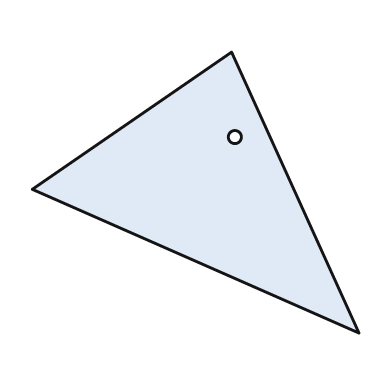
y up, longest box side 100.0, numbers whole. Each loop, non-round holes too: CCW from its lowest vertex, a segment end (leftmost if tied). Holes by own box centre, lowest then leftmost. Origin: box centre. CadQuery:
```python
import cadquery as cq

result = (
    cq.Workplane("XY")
    .moveTo(50.0, -43.0)
    .lineTo(11.0, 43.0)
    .lineTo(-50.0, 1.0)
    .close()
    .moveTo(12.0, 17.0)
    .circle(2.0)
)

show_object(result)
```